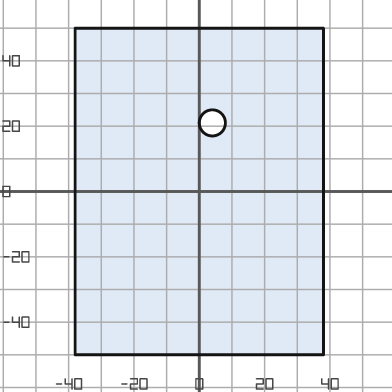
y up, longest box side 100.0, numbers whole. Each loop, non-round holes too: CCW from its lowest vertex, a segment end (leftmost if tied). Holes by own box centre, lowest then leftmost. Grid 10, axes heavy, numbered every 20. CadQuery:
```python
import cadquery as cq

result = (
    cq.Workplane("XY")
    .moveTo(-38.0, -50.0)
    .lineTo(38.0, -50.0)
    .lineTo(38.0, 50.0)
    .lineTo(-38.0, 50.0)
    .close()
    .moveTo(4.0, 21.0)
    .circle(4.0)
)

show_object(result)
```